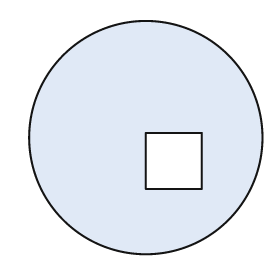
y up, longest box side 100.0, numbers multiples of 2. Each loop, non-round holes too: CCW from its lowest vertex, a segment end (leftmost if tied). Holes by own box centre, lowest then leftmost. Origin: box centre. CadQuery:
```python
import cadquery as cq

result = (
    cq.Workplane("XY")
    .moveTo(0.0, 0.0)
    .circle(50.0)
    .moveTo(0.0, -22.0)
    .lineTo(24.0, -22.0)
    .lineTo(24.0, 2.0)
    .lineTo(0.0, 2.0)
    .close()
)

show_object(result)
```